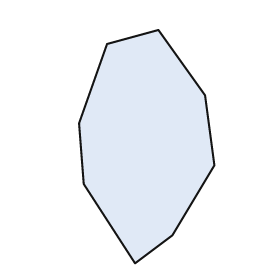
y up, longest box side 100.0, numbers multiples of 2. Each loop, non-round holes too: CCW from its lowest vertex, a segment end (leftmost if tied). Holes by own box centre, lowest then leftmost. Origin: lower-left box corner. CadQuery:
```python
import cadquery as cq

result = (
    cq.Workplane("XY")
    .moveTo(24.0, 0.0)
    .lineTo(40.0, 12.0)
    .lineTo(58.0, 42.0)
    .lineTo(54.0, 72.0)
    .lineTo(34.0, 100.0)
    .lineTo(12.0, 94.0)
    .lineTo(0.0, 60.0)
    .lineTo(2.0, 34.0)
    .close()
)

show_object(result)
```